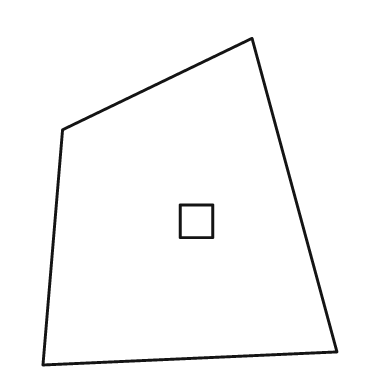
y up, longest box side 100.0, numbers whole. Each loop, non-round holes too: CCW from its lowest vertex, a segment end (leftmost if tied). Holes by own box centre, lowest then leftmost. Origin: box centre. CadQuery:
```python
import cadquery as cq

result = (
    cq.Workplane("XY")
    .moveTo(-45.0, -50.0)
    .lineTo(45.0, -46.0)
    .lineTo(19.0, 50.0)
    .lineTo(-39.0, 22.0)
    .close()
    .moveTo(-3.0, -11.0)
    .lineTo(7.0, -11.0)
    .lineTo(7.0, -1.0)
    .lineTo(-3.0, -1.0)
    .close()
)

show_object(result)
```